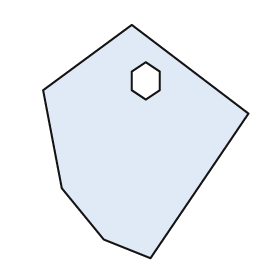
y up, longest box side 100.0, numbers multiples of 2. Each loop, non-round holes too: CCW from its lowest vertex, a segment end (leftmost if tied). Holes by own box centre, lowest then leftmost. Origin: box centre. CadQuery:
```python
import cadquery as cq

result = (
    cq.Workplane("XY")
    .moveTo(2.0, -50.0)
    .lineTo(44.0, 12.0)
    .lineTo(-6.0, 50.0)
    .lineTo(-44.0, 22.0)
    .lineTo(-36.0, -20.0)
    .lineTo(-18.0, -42.0)
    .close()
    .moveTo(0.0, 18.0)
    .lineTo(6.0, 22.0)
    .lineTo(6.0, 30.0)
    .lineTo(0.0, 34.0)
    .lineTo(-6.0, 30.0)
    .lineTo(-6.0, 22.0)
    .close()
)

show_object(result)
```